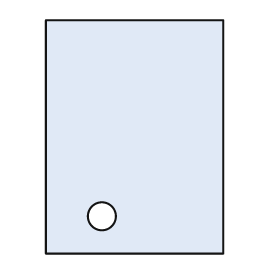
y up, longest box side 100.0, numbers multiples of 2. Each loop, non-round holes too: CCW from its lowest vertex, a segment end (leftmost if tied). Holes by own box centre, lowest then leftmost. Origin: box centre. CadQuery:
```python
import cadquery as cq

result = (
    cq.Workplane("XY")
    .moveTo(-38.0, -50.0)
    .lineTo(38.0, -50.0)
    .lineTo(38.0, 50.0)
    .lineTo(-38.0, 50.0)
    .close()
    .moveTo(-14.0, -34.0)
    .circle(6.0)
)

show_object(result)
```